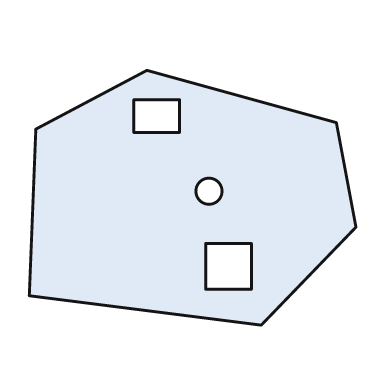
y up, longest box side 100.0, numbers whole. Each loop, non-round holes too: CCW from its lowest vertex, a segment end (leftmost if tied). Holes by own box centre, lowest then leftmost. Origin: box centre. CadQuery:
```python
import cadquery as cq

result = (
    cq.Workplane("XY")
    .moveTo(21.0, -39.0)
    .lineTo(50.0, -9.0)
    .lineTo(44.0, 23.0)
    .lineTo(-14.0, 39.0)
    .lineTo(-48.0, 21.0)
    .lineTo(-50.0, -30.0)
    .close()
    .moveTo(4.0, -28.0)
    .lineTo(18.0, -28.0)
    .lineTo(18.0, -14.0)
    .lineTo(4.0, -14.0)
    .close()
    .moveTo(5.0, 2.0)
    .circle(4.0)
    .moveTo(-18.0, 20.0)
    .lineTo(-4.0, 20.0)
    .lineTo(-4.0, 30.0)
    .lineTo(-18.0, 30.0)
    .close()
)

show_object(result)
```